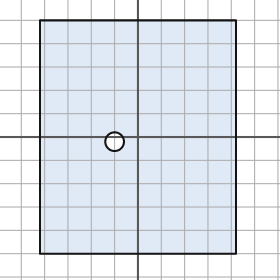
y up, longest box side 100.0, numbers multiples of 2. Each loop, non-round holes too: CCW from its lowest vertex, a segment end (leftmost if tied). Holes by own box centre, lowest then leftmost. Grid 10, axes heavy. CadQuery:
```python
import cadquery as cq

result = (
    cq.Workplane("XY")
    .moveTo(-42.0, -50.0)
    .lineTo(42.0, -50.0)
    .lineTo(42.0, 50.0)
    .lineTo(-42.0, 50.0)
    .close()
    .moveTo(-10.0, -2.0)
    .circle(4.0)
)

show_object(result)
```